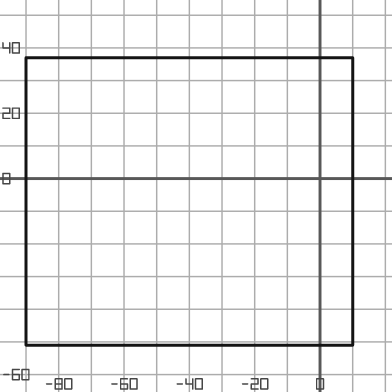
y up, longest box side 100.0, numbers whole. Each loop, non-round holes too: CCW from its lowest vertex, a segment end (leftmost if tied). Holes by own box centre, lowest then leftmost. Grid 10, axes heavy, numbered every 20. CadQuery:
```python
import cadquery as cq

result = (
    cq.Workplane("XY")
    .moveTo(-90.0, -51.0)
    .lineTo(10.0, -51.0)
    .lineTo(10.0, 37.0)
    .lineTo(-90.0, 37.0)
    .close()
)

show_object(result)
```